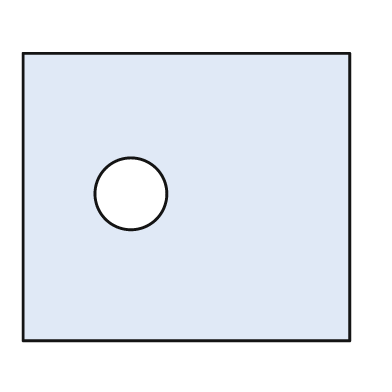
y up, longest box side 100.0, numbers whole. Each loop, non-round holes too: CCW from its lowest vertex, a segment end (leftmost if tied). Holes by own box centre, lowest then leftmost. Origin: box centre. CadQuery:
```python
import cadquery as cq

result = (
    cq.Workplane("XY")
    .moveTo(-50.0, -44.0)
    .lineTo(50.0, -44.0)
    .lineTo(50.0, 44.0)
    .lineTo(-50.0, 44.0)
    .close()
    .moveTo(-17.0, 1.0)
    .circle(11.0)
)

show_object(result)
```